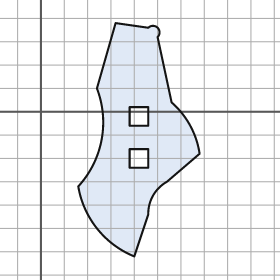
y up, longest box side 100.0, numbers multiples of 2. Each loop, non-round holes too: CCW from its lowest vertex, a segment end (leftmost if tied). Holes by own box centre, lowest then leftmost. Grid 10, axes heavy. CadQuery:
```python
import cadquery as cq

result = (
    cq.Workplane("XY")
    .moveTo(40.0, -62.0)
    .lineTo(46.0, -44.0)
    .threePointArc((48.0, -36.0), (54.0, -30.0))
    .lineTo(68.0, -18.0)
    .threePointArc((64.0, -6.0), (56.0, 4.0))
    .lineTo(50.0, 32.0)
    .threePointArc((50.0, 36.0), (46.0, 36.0))
    .lineTo(32.0, 38.0)
    .lineTo(24.0, 10.0)
    .threePointArc((26.0, -12.0), (16.0, -32.0))
    .threePointArc((24.0, -50.0), (40.0, -62.0))
    .close()
    .moveTo(38.0, -24.0)
    .lineTo(46.0, -24.0)
    .lineTo(46.0, -16.0)
    .lineTo(38.0, -16.0)
    .close()
    .moveTo(38.0, -6.0)
    .lineTo(46.0, -6.0)
    .lineTo(46.0, 2.0)
    .lineTo(38.0, 2.0)
    .close()
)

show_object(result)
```